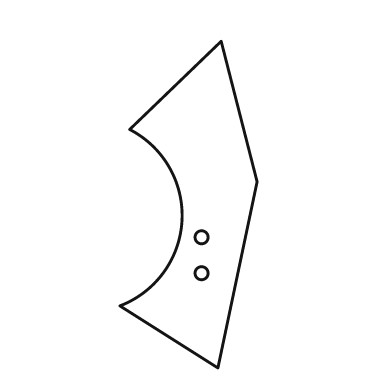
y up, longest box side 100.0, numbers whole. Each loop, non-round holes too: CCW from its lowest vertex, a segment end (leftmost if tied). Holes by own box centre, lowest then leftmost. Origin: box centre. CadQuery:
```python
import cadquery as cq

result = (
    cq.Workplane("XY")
    .moveTo(9.0, -50.0)
    .lineTo(21.0, 7.0)
    .lineTo(10.0, 50.0)
    .lineTo(-18.0, 23.0)
    .threePointArc((-2.0, -5.0), (-21.0, -31.0))
    .close()
    .moveTo(4.0, -21.0)
    .circle(2.0)
    .moveTo(4.0, -10.0)
    .circle(2.0)
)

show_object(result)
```